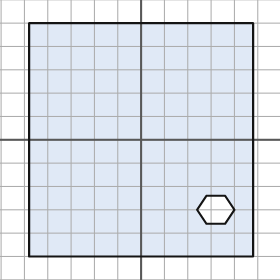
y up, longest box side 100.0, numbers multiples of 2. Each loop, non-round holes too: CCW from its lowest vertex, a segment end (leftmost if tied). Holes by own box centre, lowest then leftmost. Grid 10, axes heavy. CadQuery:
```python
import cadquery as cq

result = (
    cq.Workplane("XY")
    .moveTo(-48.0, -50.0)
    .lineTo(48.0, -50.0)
    .lineTo(48.0, 50.0)
    .lineTo(-48.0, 50.0)
    .close()
    .moveTo(28.0, -36.0)
    .lineTo(36.0, -36.0)
    .lineTo(40.0, -30.0)
    .lineTo(36.0, -24.0)
    .lineTo(28.0, -24.0)
    .lineTo(24.0, -30.0)
    .close()
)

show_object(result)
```